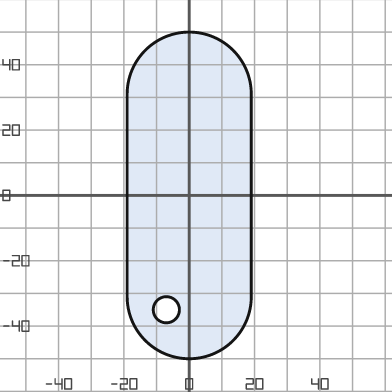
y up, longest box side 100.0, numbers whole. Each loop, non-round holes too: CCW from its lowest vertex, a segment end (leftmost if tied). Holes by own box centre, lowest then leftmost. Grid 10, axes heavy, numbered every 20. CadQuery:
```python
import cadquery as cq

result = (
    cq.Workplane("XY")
    .moveTo(-19.0, -31.0)
    .threePointArc((0.0, -50.0), (19.0, -31.0))
    .lineTo(19.0, 31.0)
    .threePointArc((0.0, 50.0), (-19.0, 31.0))
    .close()
    .moveTo(-7.0, -35.0)
    .circle(4.0)
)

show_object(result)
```